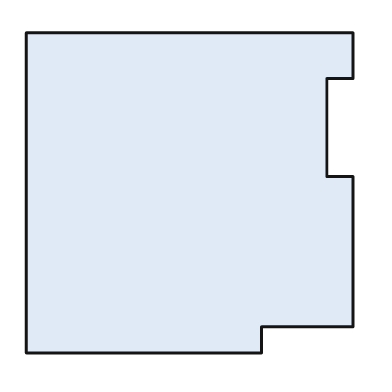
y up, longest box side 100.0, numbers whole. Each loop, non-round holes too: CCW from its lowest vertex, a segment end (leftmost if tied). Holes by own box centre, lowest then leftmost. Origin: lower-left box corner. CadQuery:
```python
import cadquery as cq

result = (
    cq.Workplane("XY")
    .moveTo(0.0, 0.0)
    .lineTo(72.0, 0.0)
    .lineTo(72.0, 8.0)
    .lineTo(100.0, 8.0)
    .lineTo(100.0, 54.0)
    .lineTo(92.0, 54.0)
    .lineTo(92.0, 84.0)
    .lineTo(100.0, 84.0)
    .lineTo(100.0, 98.0)
    .lineTo(0.0, 98.0)
    .close()
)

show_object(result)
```